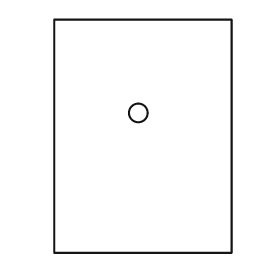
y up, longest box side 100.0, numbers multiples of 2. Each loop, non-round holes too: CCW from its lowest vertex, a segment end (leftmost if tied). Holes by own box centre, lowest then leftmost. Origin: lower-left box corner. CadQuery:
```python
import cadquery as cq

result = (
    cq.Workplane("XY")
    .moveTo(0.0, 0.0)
    .lineTo(76.0, 0.0)
    .lineTo(76.0, 100.0)
    .lineTo(0.0, 100.0)
    .close()
    .moveTo(36.0, 60.0)
    .circle(4.0)
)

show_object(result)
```